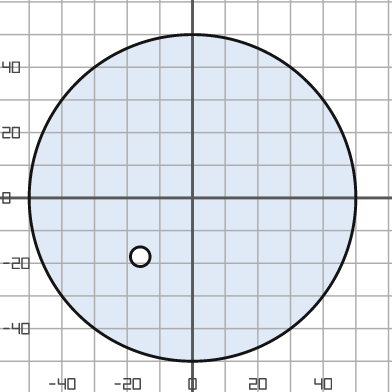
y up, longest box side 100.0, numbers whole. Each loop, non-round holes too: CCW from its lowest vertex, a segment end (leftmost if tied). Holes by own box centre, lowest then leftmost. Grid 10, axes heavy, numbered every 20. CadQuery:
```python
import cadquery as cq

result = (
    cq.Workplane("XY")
    .moveTo(0.0, 0.0)
    .circle(50.0)
    .moveTo(-16.0, -18.0)
    .circle(3.0)
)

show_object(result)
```